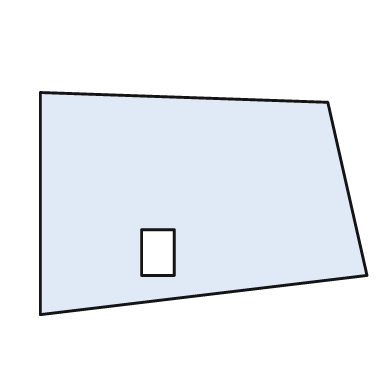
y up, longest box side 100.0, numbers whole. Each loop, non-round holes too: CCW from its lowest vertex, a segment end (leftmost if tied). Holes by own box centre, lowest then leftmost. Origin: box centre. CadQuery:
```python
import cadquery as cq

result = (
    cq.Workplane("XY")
    .moveTo(-50.0, -34.0)
    .lineTo(50.0, -22.0)
    .lineTo(38.0, 31.0)
    .lineTo(-50.0, 34.0)
    .close()
    .moveTo(-19.0, -22.0)
    .lineTo(-9.0, -22.0)
    .lineTo(-9.0, -8.0)
    .lineTo(-19.0, -8.0)
    .close()
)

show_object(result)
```